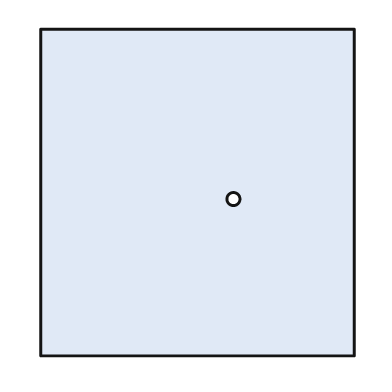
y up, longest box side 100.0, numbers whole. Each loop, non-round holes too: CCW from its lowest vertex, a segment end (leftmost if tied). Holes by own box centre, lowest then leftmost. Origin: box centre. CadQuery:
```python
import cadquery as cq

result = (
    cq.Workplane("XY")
    .moveTo(-48.0, -50.0)
    .lineTo(48.0, -50.0)
    .lineTo(48.0, 50.0)
    .lineTo(-48.0, 50.0)
    .close()
    .moveTo(11.0, -2.0)
    .circle(2.0)
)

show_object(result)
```